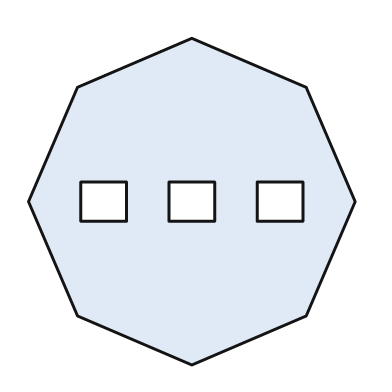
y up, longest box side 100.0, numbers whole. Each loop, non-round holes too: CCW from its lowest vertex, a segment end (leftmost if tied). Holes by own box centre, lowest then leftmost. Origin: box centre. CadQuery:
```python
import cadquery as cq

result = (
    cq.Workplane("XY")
    .moveTo(0.0, -50.0)
    .lineTo(35.0, -35.0)
    .lineTo(50.0, 0.0)
    .lineTo(35.0, 35.0)
    .lineTo(0.0, 50.0)
    .lineTo(-35.0, 35.0)
    .lineTo(-50.0, 0.0)
    .lineTo(-35.0, -35.0)
    .close()
    .moveTo(-34.0, -6.0)
    .lineTo(-20.0, -6.0)
    .lineTo(-20.0, 6.0)
    .lineTo(-34.0, 6.0)
    .close()
    .moveTo(-7.0, -6.0)
    .lineTo(7.0, -6.0)
    .lineTo(7.0, 6.0)
    .lineTo(-7.0, 6.0)
    .close()
    .moveTo(20.0, -6.0)
    .lineTo(34.0, -6.0)
    .lineTo(34.0, 6.0)
    .lineTo(20.0, 6.0)
    .close()
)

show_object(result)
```